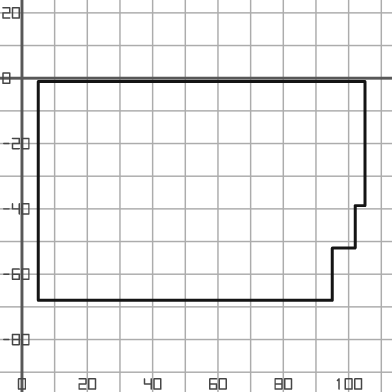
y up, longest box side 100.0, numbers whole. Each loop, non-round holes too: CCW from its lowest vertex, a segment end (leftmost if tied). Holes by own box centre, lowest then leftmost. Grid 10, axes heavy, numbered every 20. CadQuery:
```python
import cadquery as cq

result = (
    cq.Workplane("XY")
    .moveTo(5.0, -68.0)
    .lineTo(95.0, -68.0)
    .lineTo(95.0, -52.0)
    .lineTo(102.0, -52.0)
    .lineTo(102.0, -39.0)
    .lineTo(105.0, -39.0)
    .lineTo(105.0, -1.0)
    .lineTo(5.0, -1.0)
    .close()
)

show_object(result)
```